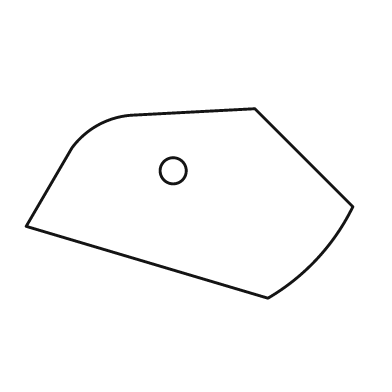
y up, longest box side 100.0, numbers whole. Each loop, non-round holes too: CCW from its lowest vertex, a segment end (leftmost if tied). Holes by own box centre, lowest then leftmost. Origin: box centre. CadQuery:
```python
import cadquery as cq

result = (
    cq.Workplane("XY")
    .moveTo(24.0, -29.0)
    .threePointArc((39.0, -17.0), (50.0, -1.0))
    .lineTo(20.0, 29.0)
    .lineTo(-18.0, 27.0)
    .threePointArc((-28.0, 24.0), (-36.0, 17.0))
    .lineTo(-50.0, -7.0)
    .close()
    .moveTo(-5.0, 10.0)
    .circle(4.0)
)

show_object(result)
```